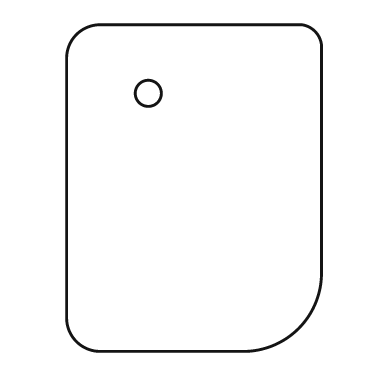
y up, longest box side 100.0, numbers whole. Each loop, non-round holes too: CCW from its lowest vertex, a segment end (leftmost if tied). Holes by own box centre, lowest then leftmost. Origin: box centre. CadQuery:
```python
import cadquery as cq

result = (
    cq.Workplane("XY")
    .moveTo(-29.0, -50.0)
    .lineTo(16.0, -50.0)
    .threePointArc((32.0, -43.0), (39.0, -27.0))
    .lineTo(39.0, 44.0)
    .threePointArc((37.0, 48.0), (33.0, 50.0))
    .lineTo(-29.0, 50.0)
    .threePointArc((-36.0, 47.0), (-39.0, 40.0))
    .lineTo(-39.0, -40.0)
    .threePointArc((-36.0, -47.0), (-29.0, -50.0))
    .close()
    .moveTo(-14.0, 29.0)
    .circle(4.0)
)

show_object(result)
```